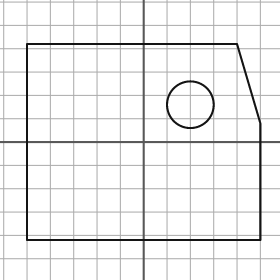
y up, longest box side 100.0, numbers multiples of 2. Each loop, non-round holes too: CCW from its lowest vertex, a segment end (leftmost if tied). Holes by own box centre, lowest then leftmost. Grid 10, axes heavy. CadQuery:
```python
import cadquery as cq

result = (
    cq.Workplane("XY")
    .moveTo(-50.0, -42.0)
    .lineTo(50.0, -42.0)
    .lineTo(50.0, 8.0)
    .lineTo(40.0, 42.0)
    .lineTo(-50.0, 42.0)
    .close()
    .moveTo(20.0, 16.0)
    .circle(10.0)
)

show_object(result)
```